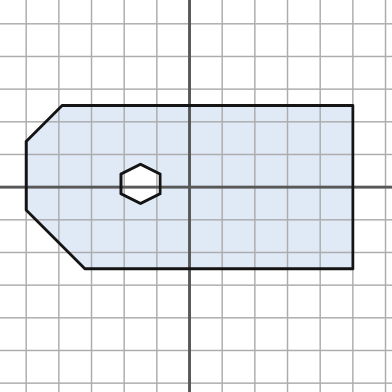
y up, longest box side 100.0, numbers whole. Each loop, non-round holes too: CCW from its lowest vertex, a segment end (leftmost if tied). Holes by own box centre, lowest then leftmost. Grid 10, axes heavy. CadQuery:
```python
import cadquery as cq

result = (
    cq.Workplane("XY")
    .moveTo(-32.0, -25.0)
    .lineTo(50.0, -25.0)
    .lineTo(50.0, 25.0)
    .lineTo(-39.0, 25.0)
    .lineTo(-50.0, 14.0)
    .lineTo(-50.0, -7.0)
    .close()
    .moveTo(-15.0, -5.0)
    .lineTo(-9.0, -2.0)
    .lineTo(-9.0, 4.0)
    .lineTo(-15.0, 7.0)
    .lineTo(-21.0, 4.0)
    .lineTo(-21.0, -2.0)
    .close()
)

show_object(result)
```